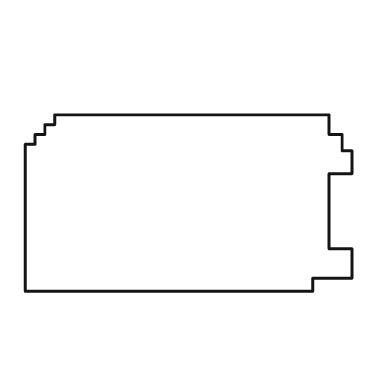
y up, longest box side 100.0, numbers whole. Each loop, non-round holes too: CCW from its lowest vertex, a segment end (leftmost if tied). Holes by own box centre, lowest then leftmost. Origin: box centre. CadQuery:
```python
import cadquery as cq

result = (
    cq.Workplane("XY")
    .moveTo(-50.0, -27.0)
    .lineTo(38.0, -27.0)
    .lineTo(38.0, -23.0)
    .lineTo(50.0, -23.0)
    .lineTo(50.0, -14.0)
    .lineTo(43.0, -14.0)
    .lineTo(43.0, 9.0)
    .lineTo(50.0, 9.0)
    .lineTo(50.0, 16.0)
    .lineTo(47.0, 16.0)
    .lineTo(47.0, 21.0)
    .lineTo(43.0, 21.0)
    .lineTo(43.0, 27.0)
    .lineTo(-41.0, 27.0)
    .lineTo(-41.0, 24.0)
    .lineTo(-44.0, 24.0)
    .lineTo(-44.0, 21.0)
    .lineTo(-47.0, 21.0)
    .lineTo(-47.0, 18.0)
    .lineTo(-50.0, 18.0)
    .close()
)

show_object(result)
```